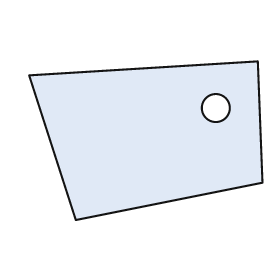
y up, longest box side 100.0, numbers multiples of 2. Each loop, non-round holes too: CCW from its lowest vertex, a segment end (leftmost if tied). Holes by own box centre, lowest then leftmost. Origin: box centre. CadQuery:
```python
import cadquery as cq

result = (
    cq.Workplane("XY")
    .moveTo(-30.0, -34.0)
    .lineTo(50.0, -18.0)
    .lineTo(48.0, 34.0)
    .lineTo(-50.0, 28.0)
    .close()
    .moveTo(30.0, 14.0)
    .circle(6.0)
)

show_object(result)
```